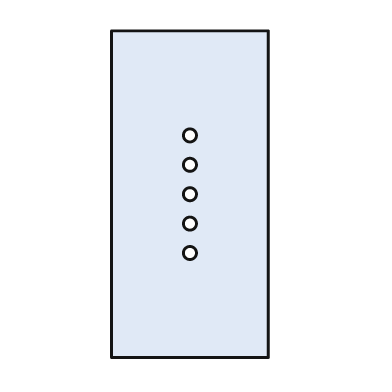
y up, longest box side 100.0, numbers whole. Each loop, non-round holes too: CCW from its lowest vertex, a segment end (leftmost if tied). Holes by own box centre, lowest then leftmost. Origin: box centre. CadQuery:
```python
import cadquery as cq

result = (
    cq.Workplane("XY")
    .moveTo(-24.0, -50.0)
    .lineTo(24.0, -50.0)
    .lineTo(24.0, 50.0)
    .lineTo(-24.0, 50.0)
    .close()
    .moveTo(0.0, -18.0)
    .circle(2.0)
    .moveTo(0.0, -9.0)
    .circle(2.0)
    .moveTo(0.0, 0.0)
    .circle(2.0)
    .moveTo(0.0, 9.0)
    .circle(2.0)
    .moveTo(0.0, 18.0)
    .circle(2.0)
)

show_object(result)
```